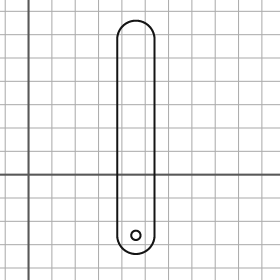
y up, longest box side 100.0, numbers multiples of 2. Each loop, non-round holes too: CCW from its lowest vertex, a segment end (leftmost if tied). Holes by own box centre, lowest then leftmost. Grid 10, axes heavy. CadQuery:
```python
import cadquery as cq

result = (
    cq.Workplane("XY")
    .moveTo(38.0, -26.0)
    .threePointArc((46.0, -34.0), (54.0, -26.0))
    .lineTo(54.0, 58.0)
    .threePointArc((46.0, 66.0), (38.0, 58.0))
    .close()
    .moveTo(46.0, -26.0)
    .circle(2.0)
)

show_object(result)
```